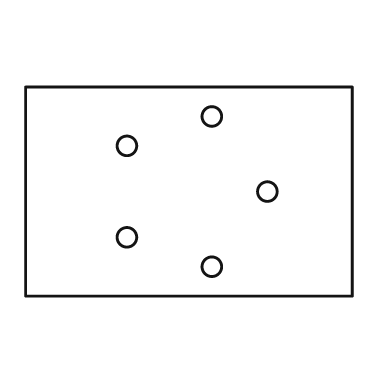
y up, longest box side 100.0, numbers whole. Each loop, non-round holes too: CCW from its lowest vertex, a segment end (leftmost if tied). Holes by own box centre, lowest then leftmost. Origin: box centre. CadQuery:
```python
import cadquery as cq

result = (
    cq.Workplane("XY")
    .moveTo(-50.0, -32.0)
    .lineTo(50.0, -32.0)
    .lineTo(50.0, 32.0)
    .lineTo(-50.0, 32.0)
    .close()
    .moveTo(7.0, -23.0)
    .circle(3.0)
    .moveTo(-19.0, -14.0)
    .circle(3.0)
    .moveTo(24.0, 0.0)
    .circle(3.0)
    .moveTo(-19.0, 14.0)
    .circle(3.0)
    .moveTo(7.0, 23.0)
    .circle(3.0)
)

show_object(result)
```